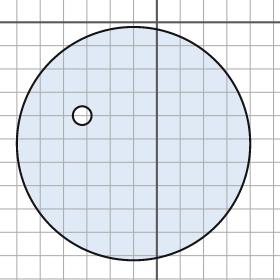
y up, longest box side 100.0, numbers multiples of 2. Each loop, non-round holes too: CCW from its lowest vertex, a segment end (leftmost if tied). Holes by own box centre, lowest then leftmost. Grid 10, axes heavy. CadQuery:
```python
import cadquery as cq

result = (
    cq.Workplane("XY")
    .moveTo(-10.0, -52.0)
    .circle(50.0)
    .moveTo(-32.0, -40.0)
    .circle(4.0)
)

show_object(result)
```